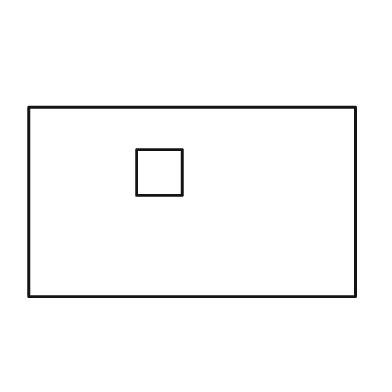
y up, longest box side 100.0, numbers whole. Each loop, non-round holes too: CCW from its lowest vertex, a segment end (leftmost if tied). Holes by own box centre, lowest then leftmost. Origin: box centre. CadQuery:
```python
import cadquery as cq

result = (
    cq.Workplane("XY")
    .moveTo(-50.0, -29.0)
    .lineTo(50.0, -29.0)
    .lineTo(50.0, 29.0)
    .lineTo(-50.0, 29.0)
    .close()
    .moveTo(-17.0, 2.0)
    .lineTo(-3.0, 2.0)
    .lineTo(-3.0, 16.0)
    .lineTo(-17.0, 16.0)
    .close()
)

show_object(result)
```